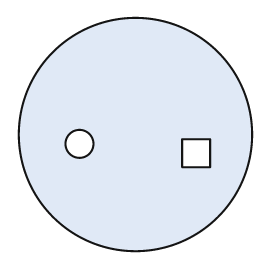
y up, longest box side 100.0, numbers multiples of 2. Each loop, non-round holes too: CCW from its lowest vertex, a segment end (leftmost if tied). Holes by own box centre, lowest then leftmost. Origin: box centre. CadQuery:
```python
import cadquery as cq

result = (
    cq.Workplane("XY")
    .moveTo(0.0, 0.0)
    .circle(50.0)
    .moveTo(20.0, -14.0)
    .lineTo(32.0, -14.0)
    .lineTo(32.0, -2.0)
    .lineTo(20.0, -2.0)
    .close()
    .moveTo(-24.0, -4.0)
    .circle(6.0)
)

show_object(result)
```